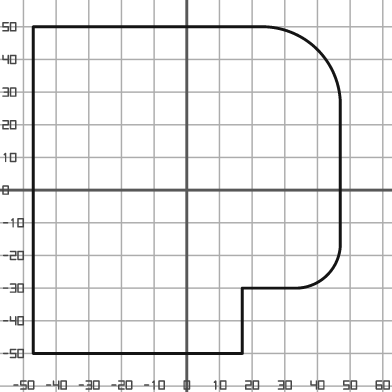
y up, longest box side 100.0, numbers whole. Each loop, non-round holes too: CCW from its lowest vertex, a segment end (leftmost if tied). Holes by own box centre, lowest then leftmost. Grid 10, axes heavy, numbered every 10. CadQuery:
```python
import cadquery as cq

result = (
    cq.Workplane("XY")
    .moveTo(-47.0, -50.0)
    .lineTo(17.0, -50.0)
    .lineTo(17.0, -30.0)
    .lineTo(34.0, -30.0)
    .threePointArc((43.0, -26.0), (47.0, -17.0))
    .lineTo(47.0, 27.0)
    .threePointArc((40.0, 43.0), (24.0, 50.0))
    .lineTo(-47.0, 50.0)
    .close()
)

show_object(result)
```